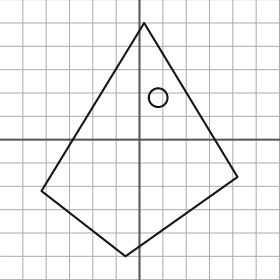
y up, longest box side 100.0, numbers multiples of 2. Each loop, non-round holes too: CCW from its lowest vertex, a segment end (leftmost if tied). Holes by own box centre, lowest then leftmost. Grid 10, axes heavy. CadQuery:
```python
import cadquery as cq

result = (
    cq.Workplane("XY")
    .moveTo(-6.0, -50.0)
    .lineTo(42.0, -16.0)
    .lineTo(2.0, 50.0)
    .lineTo(-42.0, -22.0)
    .close()
    .moveTo(8.0, 18.0)
    .circle(4.0)
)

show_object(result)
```